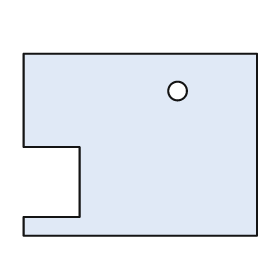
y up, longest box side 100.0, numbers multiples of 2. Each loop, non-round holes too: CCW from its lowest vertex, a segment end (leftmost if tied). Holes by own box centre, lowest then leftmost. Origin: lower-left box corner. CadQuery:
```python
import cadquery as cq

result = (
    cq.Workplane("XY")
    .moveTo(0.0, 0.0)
    .lineTo(100.0, 0.0)
    .lineTo(100.0, 78.0)
    .lineTo(0.0, 78.0)
    .lineTo(0.0, 38.0)
    .lineTo(24.0, 38.0)
    .lineTo(24.0, 8.0)
    .lineTo(0.0, 8.0)
    .close()
    .moveTo(66.0, 62.0)
    .circle(4.0)
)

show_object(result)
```